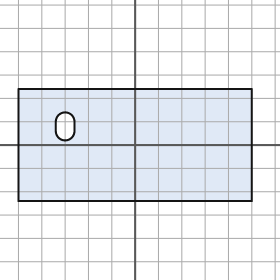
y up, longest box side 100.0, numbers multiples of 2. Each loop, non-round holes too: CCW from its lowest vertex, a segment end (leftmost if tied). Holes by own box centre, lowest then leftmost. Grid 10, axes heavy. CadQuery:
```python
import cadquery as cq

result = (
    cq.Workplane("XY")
    .moveTo(-50.0, -24.0)
    .lineTo(50.0, -24.0)
    .lineTo(50.0, 24.0)
    .lineTo(-50.0, 24.0)
    .close()
    .moveTo(-34.0, 6.0)
    .threePointArc((-30.0, 2.0), (-26.0, 6.0))
    .lineTo(-26.0, 10.0)
    .threePointArc((-30.0, 14.0), (-34.0, 10.0))
    .close()
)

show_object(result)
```